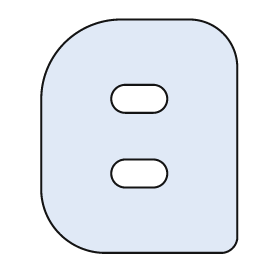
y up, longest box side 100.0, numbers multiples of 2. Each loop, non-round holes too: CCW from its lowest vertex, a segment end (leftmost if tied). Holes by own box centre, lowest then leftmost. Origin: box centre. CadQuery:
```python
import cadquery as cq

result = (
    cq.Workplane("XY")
    .moveTo(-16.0, -50.0)
    .lineTo(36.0, -50.0)
    .threePointArc((40.0, -48.0), (42.0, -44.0))
    .lineTo(42.0, 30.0)
    .threePointArc((36.0, 44.0), (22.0, 50.0))
    .lineTo(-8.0, 50.0)
    .threePointArc((-32.0, 40.0), (-42.0, 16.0))
    .lineTo(-42.0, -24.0)
    .threePointArc((-34.0, -42.0), (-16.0, -50.0))
    .close()
    .moveTo(-6.0, -22.0)
    .lineTo(6.0, -22.0)
    .threePointArc((12.0, -16.0), (6.0, -10.0))
    .lineTo(-6.0, -10.0)
    .threePointArc((-12.0, -16.0), (-6.0, -22.0))
    .close()
    .moveTo(-6.0, 10.0)
    .lineTo(6.0, 10.0)
    .threePointArc((12.0, 16.0), (6.0, 22.0))
    .lineTo(-6.0, 22.0)
    .threePointArc((-12.0, 16.0), (-6.0, 10.0))
    .close()
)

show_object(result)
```